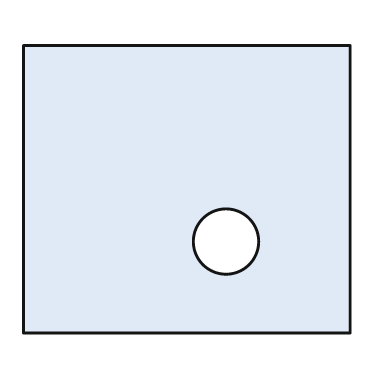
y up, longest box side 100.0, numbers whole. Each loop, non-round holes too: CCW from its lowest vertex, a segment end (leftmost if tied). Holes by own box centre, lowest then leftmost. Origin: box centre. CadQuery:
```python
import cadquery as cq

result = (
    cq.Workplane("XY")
    .moveTo(-50.0, -44.0)
    .lineTo(50.0, -44.0)
    .lineTo(50.0, 44.0)
    .lineTo(-50.0, 44.0)
    .close()
    .moveTo(12.0, -16.0)
    .circle(10.0)
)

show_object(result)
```